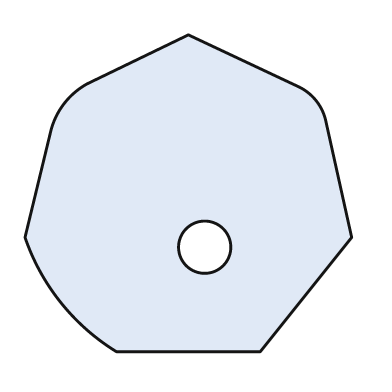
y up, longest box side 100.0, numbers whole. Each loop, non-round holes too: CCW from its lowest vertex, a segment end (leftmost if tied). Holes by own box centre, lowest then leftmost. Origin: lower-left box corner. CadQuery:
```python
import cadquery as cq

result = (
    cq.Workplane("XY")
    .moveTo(28.0, 0.0)
    .lineTo(72.0, 0.0)
    .lineTo(100.0, 35.0)
    .lineTo(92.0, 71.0)
    .threePointArc((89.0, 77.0), (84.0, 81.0))
    .lineTo(50.0, 97.0)
    .lineTo(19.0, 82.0)
    .threePointArc((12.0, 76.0), (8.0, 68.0))
    .lineTo(0.0, 35.0)
    .threePointArc((11.0, 15.0), (28.0, 0.0))
    .close()
    .moveTo(55.0, 32.0)
    .circle(8.0)
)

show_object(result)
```